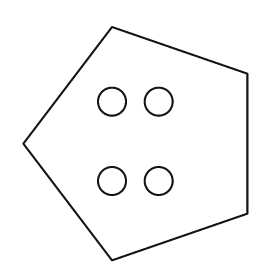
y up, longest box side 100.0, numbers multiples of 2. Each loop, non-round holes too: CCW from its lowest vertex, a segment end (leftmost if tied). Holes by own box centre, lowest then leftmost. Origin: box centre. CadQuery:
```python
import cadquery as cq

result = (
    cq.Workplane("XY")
    .moveTo(-10.0, -50.0)
    .lineTo(48.0, -30.0)
    .lineTo(48.0, 30.0)
    .lineTo(-10.0, 50.0)
    .lineTo(-48.0, 0.0)
    .close()
    .moveTo(-10.0, -16.0)
    .circle(6.0)
    .moveTo(10.0, -16.0)
    .circle(6.0)
    .moveTo(-10.0, 18.0)
    .circle(6.0)
    .moveTo(10.0, 18.0)
    .circle(6.0)
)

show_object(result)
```